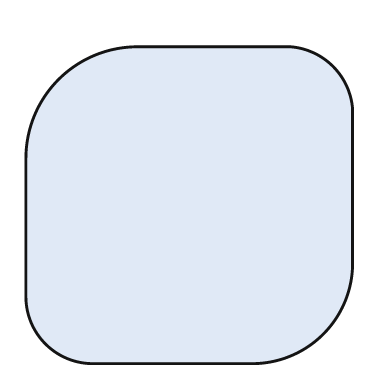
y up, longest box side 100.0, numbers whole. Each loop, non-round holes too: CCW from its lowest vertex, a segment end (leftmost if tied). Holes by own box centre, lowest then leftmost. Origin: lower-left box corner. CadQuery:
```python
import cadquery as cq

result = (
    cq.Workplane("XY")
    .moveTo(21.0, 0.0)
    .lineTo(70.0, 0.0)
    .threePointArc((91.0, 9.0), (100.0, 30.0))
    .lineTo(100.0, 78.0)
    .threePointArc((94.0, 91.0), (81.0, 97.0))
    .lineTo(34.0, 97.0)
    .threePointArc((10.0, 87.0), (0.0, 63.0))
    .lineTo(0.0, 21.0)
    .threePointArc((6.0, 6.0), (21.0, 0.0))
    .close()
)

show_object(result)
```